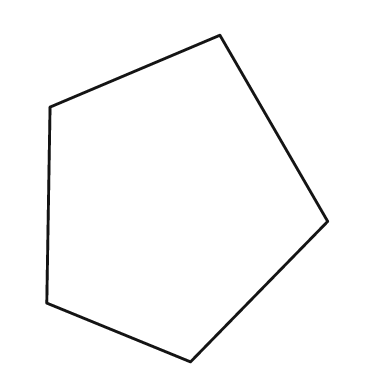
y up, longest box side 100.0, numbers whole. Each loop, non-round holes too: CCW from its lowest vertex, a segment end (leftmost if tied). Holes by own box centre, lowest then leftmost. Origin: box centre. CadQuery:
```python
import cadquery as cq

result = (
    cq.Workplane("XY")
    .moveTo(1.0, -50.0)
    .lineTo(43.0, -7.0)
    .lineTo(10.0, 50.0)
    .lineTo(-42.0, 28.0)
    .lineTo(-43.0, -32.0)
    .close()
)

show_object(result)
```